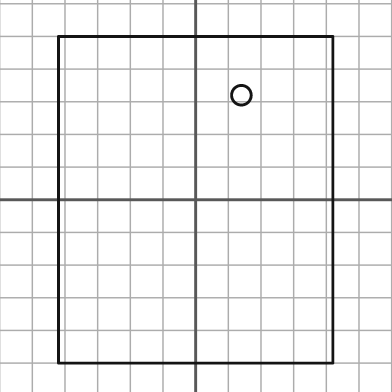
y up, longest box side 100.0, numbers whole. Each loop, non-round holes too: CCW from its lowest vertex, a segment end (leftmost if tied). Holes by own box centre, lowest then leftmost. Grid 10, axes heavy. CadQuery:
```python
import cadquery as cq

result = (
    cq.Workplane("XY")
    .moveTo(-42.0, -50.0)
    .lineTo(42.0, -50.0)
    .lineTo(42.0, 50.0)
    .lineTo(-42.0, 50.0)
    .close()
    .moveTo(14.0, 32.0)
    .circle(3.0)
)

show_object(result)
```